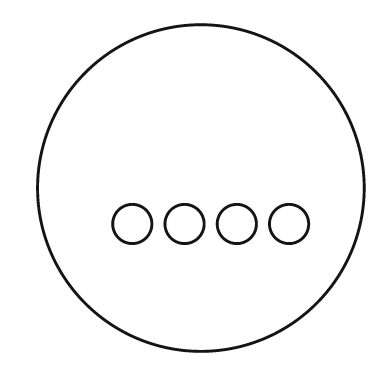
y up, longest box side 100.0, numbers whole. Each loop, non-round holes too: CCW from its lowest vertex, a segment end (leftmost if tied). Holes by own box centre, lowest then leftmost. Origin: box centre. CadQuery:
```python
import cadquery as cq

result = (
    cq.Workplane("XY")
    .moveTo(0.0, 0.0)
    .circle(50.0)
    .moveTo(-21.0, -11.0)
    .circle(6.0)
    .moveTo(-5.0, -11.0)
    .circle(6.0)
    .moveTo(11.0, -11.0)
    .circle(6.0)
    .moveTo(27.0, -11.0)
    .circle(6.0)
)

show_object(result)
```